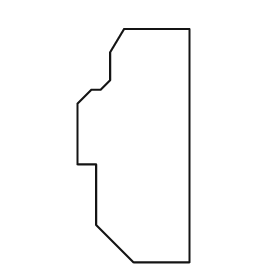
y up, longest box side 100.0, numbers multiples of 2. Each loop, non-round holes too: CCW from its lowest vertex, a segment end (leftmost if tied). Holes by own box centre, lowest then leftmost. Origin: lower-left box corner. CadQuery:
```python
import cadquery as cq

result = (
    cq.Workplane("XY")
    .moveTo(24.0, 0.0)
    .lineTo(48.0, 0.0)
    .lineTo(48.0, 100.0)
    .lineTo(20.0, 100.0)
    .lineTo(14.0, 90.0)
    .lineTo(14.0, 78.0)
    .lineTo(10.0, 74.0)
    .lineTo(6.0, 74.0)
    .lineTo(0.0, 68.0)
    .lineTo(0.0, 42.0)
    .lineTo(8.0, 42.0)
    .lineTo(8.0, 16.0)
    .close()
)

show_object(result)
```